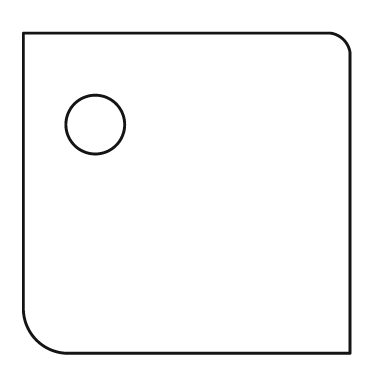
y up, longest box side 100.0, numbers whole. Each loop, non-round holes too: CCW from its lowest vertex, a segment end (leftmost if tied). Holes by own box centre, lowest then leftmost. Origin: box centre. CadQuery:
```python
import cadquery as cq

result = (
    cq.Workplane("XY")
    .moveTo(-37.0, -49.0)
    .lineTo(50.0, -49.0)
    .lineTo(50.0, 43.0)
    .threePointArc((48.0, 47.0), (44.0, 49.0))
    .lineTo(-50.0, 49.0)
    .lineTo(-50.0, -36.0)
    .threePointArc((-46.0, -45.0), (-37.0, -49.0))
    .close()
    .moveTo(-28.0, 21.0)
    .circle(9.0)
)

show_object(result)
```